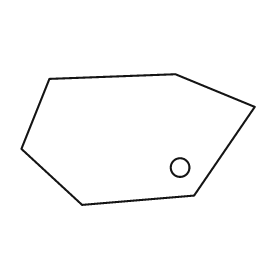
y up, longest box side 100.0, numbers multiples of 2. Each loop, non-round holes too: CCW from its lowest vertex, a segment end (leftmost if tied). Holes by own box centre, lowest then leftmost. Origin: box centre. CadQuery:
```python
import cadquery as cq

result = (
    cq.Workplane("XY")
    .moveTo(-24.0, -28.0)
    .lineTo(24.0, -24.0)
    .lineTo(50.0, 14.0)
    .lineTo(16.0, 28.0)
    .lineTo(-38.0, 26.0)
    .lineTo(-50.0, -4.0)
    .close()
    .moveTo(18.0, -12.0)
    .circle(4.0)
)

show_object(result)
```